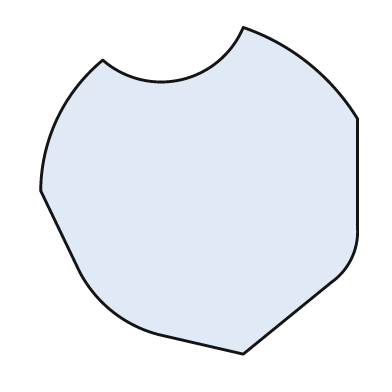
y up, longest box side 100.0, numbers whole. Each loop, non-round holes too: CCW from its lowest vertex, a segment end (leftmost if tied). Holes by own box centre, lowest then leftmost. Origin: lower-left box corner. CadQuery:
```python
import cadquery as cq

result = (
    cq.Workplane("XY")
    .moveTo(62.0, 0.0)
    .lineTo(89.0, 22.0)
    .threePointArc((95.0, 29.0), (97.0, 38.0))
    .lineTo(97.0, 72.0)
    .threePointArc((82.0, 89.0), (62.0, 100.0))
    .threePointArc((43.0, 84.0), (19.0, 90.0))
    .threePointArc((5.0, 72.0), (0.0, 50.0))
    .lineTo(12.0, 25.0)
    .threePointArc((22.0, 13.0), (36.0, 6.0))
    .close()
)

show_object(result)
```